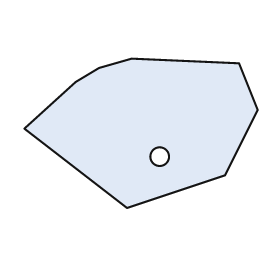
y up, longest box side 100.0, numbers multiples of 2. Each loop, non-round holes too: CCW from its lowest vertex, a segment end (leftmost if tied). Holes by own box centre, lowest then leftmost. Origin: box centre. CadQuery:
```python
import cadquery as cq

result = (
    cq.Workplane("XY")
    .moveTo(-6.0, -32.0)
    .lineTo(36.0, -18.0)
    .lineTo(50.0, 10.0)
    .lineTo(42.0, 30.0)
    .lineTo(-4.0, 32.0)
    .lineTo(-18.0, 28.0)
    .lineTo(-28.0, 22.0)
    .lineTo(-50.0, 2.0)
    .close()
    .moveTo(8.0, -10.0)
    .circle(4.0)
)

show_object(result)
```